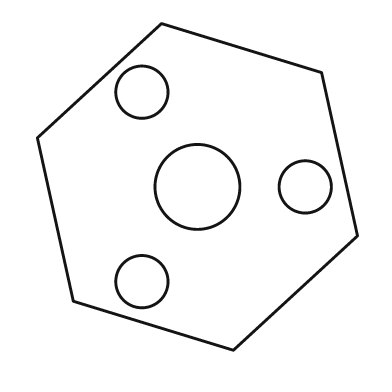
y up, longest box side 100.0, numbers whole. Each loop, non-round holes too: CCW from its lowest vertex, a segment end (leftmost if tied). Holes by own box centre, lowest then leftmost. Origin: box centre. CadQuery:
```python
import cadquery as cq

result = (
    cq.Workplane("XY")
    .moveTo(11.0, -50.0)
    .lineTo(49.0, -15.0)
    .lineTo(38.0, 35.0)
    .lineTo(-11.0, 50.0)
    .lineTo(-49.0, 15.0)
    .lineTo(-38.0, -35.0)
    .close()
    .moveTo(-17.0, -29.0)
    .circle(8.0)
    .moveTo(0.0, 0.0)
    .circle(13.0)
    .moveTo(33.0, 0.0)
    .circle(8.0)
    .moveTo(-17.0, 29.0)
    .circle(8.0)
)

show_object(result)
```